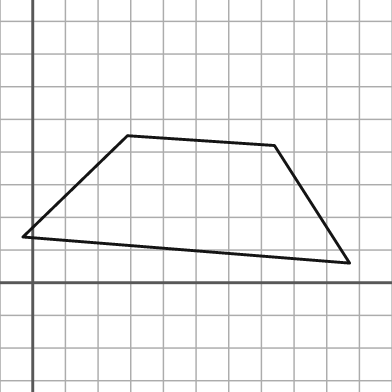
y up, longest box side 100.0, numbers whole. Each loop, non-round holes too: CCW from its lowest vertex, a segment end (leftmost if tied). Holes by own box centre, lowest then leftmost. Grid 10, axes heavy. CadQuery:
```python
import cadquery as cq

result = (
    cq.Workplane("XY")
    .moveTo(97.0, 6.0)
    .lineTo(74.0, 42.0)
    .lineTo(29.0, 45.0)
    .lineTo(-3.0, 14.0)
    .close()
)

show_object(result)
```